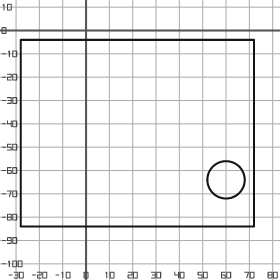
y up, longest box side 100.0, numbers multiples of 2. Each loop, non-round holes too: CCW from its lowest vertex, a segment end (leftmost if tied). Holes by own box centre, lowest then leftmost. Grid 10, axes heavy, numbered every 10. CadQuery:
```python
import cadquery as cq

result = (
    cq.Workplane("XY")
    .moveTo(-28.0, -84.0)
    .lineTo(72.0, -84.0)
    .lineTo(72.0, -4.0)
    .lineTo(-28.0, -4.0)
    .close()
    .moveTo(60.0, -64.0)
    .circle(8.0)
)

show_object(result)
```